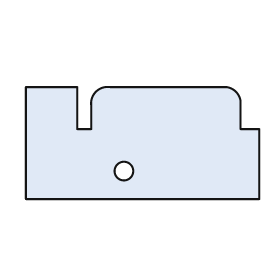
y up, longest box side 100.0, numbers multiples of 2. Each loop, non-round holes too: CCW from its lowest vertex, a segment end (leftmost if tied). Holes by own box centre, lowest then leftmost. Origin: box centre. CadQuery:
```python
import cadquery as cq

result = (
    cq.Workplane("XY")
    .moveTo(-50.0, -24.0)
    .lineTo(50.0, -24.0)
    .lineTo(50.0, 6.0)
    .lineTo(42.0, 6.0)
    .lineTo(42.0, 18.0)
    .threePointArc((40.0, 22.0), (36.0, 24.0))
    .lineTo(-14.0, 24.0)
    .threePointArc((-20.0, 22.0), (-22.0, 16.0))
    .lineTo(-22.0, 6.0)
    .lineTo(-28.0, 6.0)
    .lineTo(-28.0, 24.0)
    .lineTo(-50.0, 24.0)
    .close()
    .moveTo(-8.0, -12.0)
    .circle(4.0)
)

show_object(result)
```